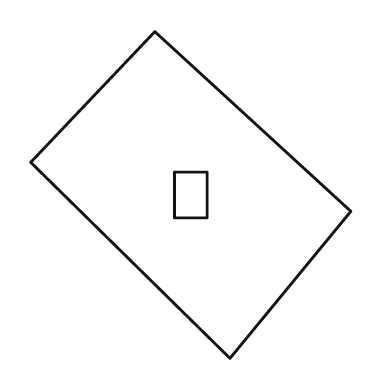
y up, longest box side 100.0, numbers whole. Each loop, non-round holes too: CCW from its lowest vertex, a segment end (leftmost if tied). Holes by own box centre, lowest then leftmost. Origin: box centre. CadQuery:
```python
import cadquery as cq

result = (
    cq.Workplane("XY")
    .moveTo(12.0, -50.0)
    .lineTo(49.0, -5.0)
    .lineTo(-11.0, 50.0)
    .lineTo(-49.0, 10.0)
    .close()
    .moveTo(-5.0, -7.0)
    .lineTo(5.0, -7.0)
    .lineTo(5.0, 7.0)
    .lineTo(-5.0, 7.0)
    .close()
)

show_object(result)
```